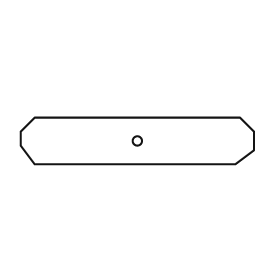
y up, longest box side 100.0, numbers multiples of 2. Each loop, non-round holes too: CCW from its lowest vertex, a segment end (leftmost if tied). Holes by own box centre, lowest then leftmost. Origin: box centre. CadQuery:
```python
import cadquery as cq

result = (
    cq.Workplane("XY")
    .moveTo(-44.0, -10.0)
    .lineTo(42.0, -10.0)
    .lineTo(50.0, -4.0)
    .lineTo(50.0, 4.0)
    .lineTo(44.0, 10.0)
    .lineTo(-44.0, 10.0)
    .lineTo(-50.0, 4.0)
    .lineTo(-50.0, -2.0)
    .close()
    .moveTo(0.0, 0.0)
    .circle(2.0)
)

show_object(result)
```